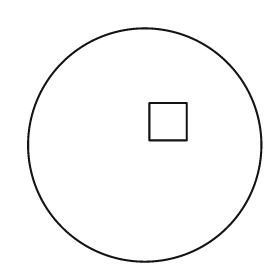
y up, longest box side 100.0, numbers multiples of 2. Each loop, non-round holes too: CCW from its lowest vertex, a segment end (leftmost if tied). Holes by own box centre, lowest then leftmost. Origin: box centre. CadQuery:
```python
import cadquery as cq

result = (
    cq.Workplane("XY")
    .moveTo(0.0, 0.0)
    .circle(50.0)
    .moveTo(2.0, 2.0)
    .lineTo(18.0, 2.0)
    .lineTo(18.0, 18.0)
    .lineTo(2.0, 18.0)
    .close()
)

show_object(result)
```